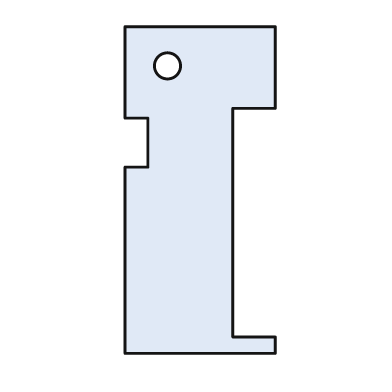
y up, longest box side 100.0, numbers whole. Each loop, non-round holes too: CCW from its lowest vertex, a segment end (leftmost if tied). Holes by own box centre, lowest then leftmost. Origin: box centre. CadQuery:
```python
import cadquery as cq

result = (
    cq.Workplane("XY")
    .moveTo(-23.0, -50.0)
    .lineTo(23.0, -50.0)
    .lineTo(23.0, -45.0)
    .lineTo(10.0, -45.0)
    .lineTo(10.0, 25.0)
    .lineTo(23.0, 25.0)
    .lineTo(23.0, 50.0)
    .lineTo(-23.0, 50.0)
    .lineTo(-23.0, 22.0)
    .lineTo(-16.0, 22.0)
    .lineTo(-16.0, 7.0)
    .lineTo(-23.0, 7.0)
    .close()
    .moveTo(-10.0, 38.0)
    .circle(4.0)
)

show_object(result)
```